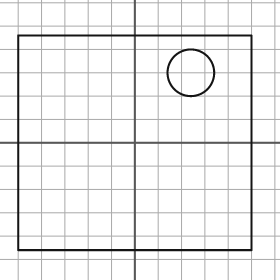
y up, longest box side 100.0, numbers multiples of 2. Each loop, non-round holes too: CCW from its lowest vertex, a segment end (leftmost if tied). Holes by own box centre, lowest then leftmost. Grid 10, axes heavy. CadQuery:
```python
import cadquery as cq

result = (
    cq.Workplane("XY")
    .moveTo(-50.0, -46.0)
    .lineTo(50.0, -46.0)
    .lineTo(50.0, 46.0)
    .lineTo(-50.0, 46.0)
    .close()
    .moveTo(24.0, 30.0)
    .circle(10.0)
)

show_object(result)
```